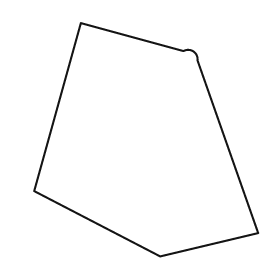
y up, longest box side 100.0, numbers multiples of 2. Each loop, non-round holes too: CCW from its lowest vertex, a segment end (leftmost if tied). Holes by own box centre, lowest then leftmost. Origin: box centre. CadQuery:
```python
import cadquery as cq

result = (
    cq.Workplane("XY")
    .moveTo(6.0, -50.0)
    .lineTo(48.0, -40.0)
    .lineTo(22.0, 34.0)
    .threePointArc((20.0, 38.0), (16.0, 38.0))
    .lineTo(-28.0, 50.0)
    .lineTo(-48.0, -22.0)
    .close()
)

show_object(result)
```